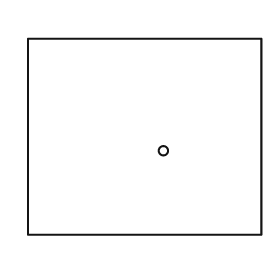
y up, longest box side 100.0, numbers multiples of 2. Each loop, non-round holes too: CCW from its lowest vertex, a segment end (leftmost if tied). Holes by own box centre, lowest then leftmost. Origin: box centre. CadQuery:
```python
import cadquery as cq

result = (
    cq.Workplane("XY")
    .moveTo(-50.0, -42.0)
    .lineTo(50.0, -42.0)
    .lineTo(50.0, 42.0)
    .lineTo(-50.0, 42.0)
    .close()
    .moveTo(8.0, -6.0)
    .circle(2.0)
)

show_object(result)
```